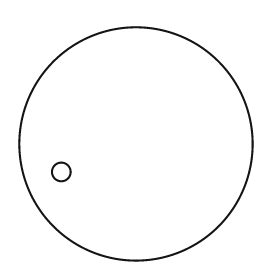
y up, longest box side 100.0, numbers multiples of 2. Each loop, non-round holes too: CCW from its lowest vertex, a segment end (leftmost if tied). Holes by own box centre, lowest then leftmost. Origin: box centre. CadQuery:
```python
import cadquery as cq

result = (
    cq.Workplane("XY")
    .moveTo(0.0, 0.0)
    .circle(50.0)
    .moveTo(-32.0, -12.0)
    .circle(4.0)
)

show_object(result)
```